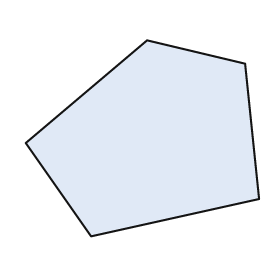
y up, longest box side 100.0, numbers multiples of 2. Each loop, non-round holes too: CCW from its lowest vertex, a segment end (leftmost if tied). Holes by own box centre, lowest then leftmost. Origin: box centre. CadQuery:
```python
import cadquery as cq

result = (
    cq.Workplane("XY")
    .moveTo(-22.0, -42.0)
    .lineTo(50.0, -26.0)
    .lineTo(44.0, 32.0)
    .lineTo(2.0, 42.0)
    .lineTo(-50.0, -2.0)
    .close()
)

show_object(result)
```